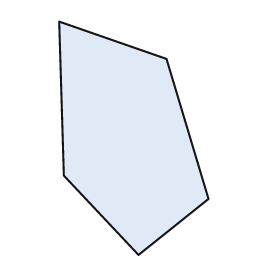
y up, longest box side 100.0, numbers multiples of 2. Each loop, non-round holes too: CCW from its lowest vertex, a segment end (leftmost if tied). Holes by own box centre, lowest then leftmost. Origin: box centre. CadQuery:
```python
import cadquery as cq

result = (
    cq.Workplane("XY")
    .moveTo(2.0, -50.0)
    .lineTo(32.0, -26.0)
    .lineTo(14.0, 34.0)
    .lineTo(-32.0, 50.0)
    .lineTo(-30.0, -16.0)
    .close()
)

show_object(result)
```